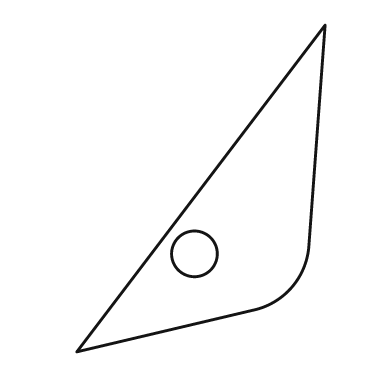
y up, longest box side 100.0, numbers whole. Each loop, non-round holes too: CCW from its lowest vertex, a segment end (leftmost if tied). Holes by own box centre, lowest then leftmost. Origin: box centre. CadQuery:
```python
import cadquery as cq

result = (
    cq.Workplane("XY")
    .moveTo(-38.0, -50.0)
    .lineTo(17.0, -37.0)
    .threePointArc((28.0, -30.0), (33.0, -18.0))
    .lineTo(38.0, 50.0)
    .close()
    .moveTo(-2.0, -20.0)
    .circle(7.0)
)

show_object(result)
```